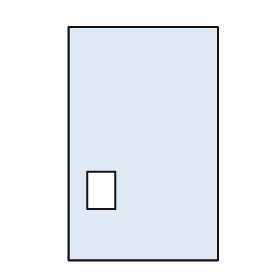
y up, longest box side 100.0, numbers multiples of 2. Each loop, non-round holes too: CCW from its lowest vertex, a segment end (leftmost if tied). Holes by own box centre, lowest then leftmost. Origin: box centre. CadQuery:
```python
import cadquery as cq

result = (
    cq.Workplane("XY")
    .moveTo(-32.0, -50.0)
    .lineTo(32.0, -50.0)
    .lineTo(32.0, 50.0)
    .lineTo(-32.0, 50.0)
    .close()
    .moveTo(-24.0, -28.0)
    .lineTo(-12.0, -28.0)
    .lineTo(-12.0, -12.0)
    .lineTo(-24.0, -12.0)
    .close()
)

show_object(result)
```